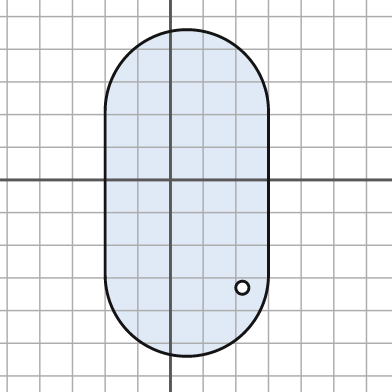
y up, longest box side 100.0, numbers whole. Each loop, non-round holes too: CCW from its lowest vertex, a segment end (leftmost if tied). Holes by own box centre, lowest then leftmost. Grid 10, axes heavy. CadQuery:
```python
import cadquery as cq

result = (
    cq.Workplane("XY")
    .moveTo(-20.0, -29.0)
    .threePointArc((5.0, -54.0), (30.0, -29.0))
    .lineTo(30.0, 21.0)
    .threePointArc((5.0, 46.0), (-20.0, 21.0))
    .close()
    .moveTo(22.0, -33.0)
    .circle(2.0)
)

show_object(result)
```